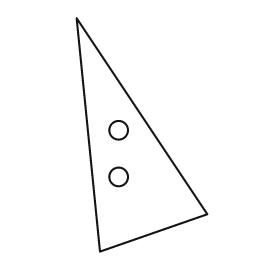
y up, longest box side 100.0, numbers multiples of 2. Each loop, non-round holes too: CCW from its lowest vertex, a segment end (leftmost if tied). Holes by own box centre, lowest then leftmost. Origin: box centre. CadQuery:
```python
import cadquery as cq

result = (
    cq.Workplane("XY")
    .moveTo(-18.0, -50.0)
    .lineTo(28.0, -34.0)
    .lineTo(-28.0, 50.0)
    .close()
    .moveTo(-10.0, -18.0)
    .circle(4.0)
    .moveTo(-10.0, 2.0)
    .circle(4.0)
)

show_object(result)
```